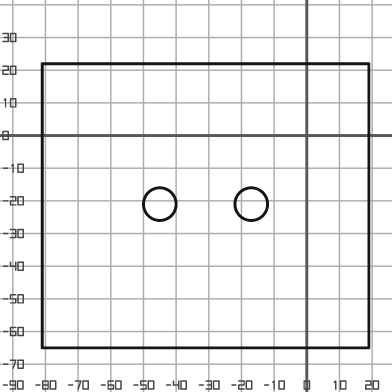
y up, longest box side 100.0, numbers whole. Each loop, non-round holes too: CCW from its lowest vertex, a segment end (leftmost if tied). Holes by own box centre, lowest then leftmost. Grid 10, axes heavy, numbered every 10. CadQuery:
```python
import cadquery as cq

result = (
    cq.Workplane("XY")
    .moveTo(-81.0, -65.0)
    .lineTo(19.0, -65.0)
    .lineTo(19.0, 22.0)
    .lineTo(-81.0, 22.0)
    .close()
    .moveTo(-45.0, -21.0)
    .circle(5.0)
    .moveTo(-17.0, -21.0)
    .circle(5.0)
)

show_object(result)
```